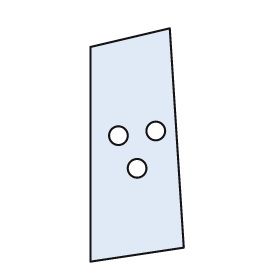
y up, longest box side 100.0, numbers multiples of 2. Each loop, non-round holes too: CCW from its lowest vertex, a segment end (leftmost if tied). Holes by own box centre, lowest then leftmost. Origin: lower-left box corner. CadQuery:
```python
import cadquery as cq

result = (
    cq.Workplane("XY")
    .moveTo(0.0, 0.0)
    .lineTo(40.0, 6.0)
    .lineTo(34.0, 100.0)
    .lineTo(0.0, 92.0)
    .close()
    .moveTo(20.0, 40.0)
    .circle(4.0)
    .moveTo(12.0, 54.0)
    .circle(4.0)
    .moveTo(28.0, 56.0)
    .circle(4.0)
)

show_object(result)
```